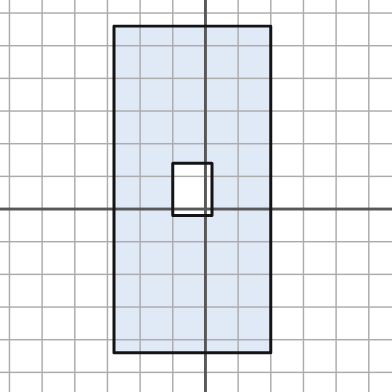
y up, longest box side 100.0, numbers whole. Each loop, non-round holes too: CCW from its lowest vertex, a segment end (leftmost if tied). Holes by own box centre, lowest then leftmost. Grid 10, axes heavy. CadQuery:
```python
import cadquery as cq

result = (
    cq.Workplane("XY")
    .moveTo(-28.0, -44.0)
    .lineTo(20.0, -44.0)
    .lineTo(20.0, 56.0)
    .lineTo(-28.0, 56.0)
    .close()
    .moveTo(-10.0, -2.0)
    .lineTo(2.0, -2.0)
    .lineTo(2.0, 14.0)
    .lineTo(-10.0, 14.0)
    .close()
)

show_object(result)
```